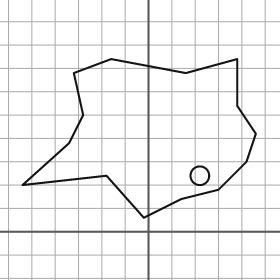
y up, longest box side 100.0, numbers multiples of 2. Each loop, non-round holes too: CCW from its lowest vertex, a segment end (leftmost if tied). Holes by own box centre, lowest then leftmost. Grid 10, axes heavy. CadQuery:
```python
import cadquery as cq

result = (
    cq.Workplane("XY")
    .moveTo(-2.0, 6.0)
    .lineTo(14.0, 14.0)
    .lineTo(30.0, 18.0)
    .lineTo(42.0, 30.0)
    .lineTo(46.0, 42.0)
    .lineTo(38.0, 54.0)
    .lineTo(38.0, 74.0)
    .lineTo(16.0, 68.0)
    .lineTo(-16.0, 74.0)
    .lineTo(-32.0, 68.0)
    .lineTo(-28.0, 50.0)
    .lineTo(-34.0, 38.0)
    .lineTo(-54.0, 20.0)
    .lineTo(-18.0, 24.0)
    .close()
    .moveTo(22.0, 24.0)
    .circle(4.0)
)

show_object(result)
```